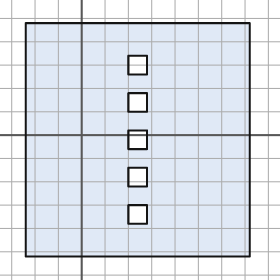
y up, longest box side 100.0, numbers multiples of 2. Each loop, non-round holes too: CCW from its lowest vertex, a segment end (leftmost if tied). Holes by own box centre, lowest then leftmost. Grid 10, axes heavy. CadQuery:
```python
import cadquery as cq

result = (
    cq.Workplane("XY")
    .moveTo(-24.0, -52.0)
    .lineTo(72.0, -52.0)
    .lineTo(72.0, 48.0)
    .lineTo(-24.0, 48.0)
    .close()
    .moveTo(20.0, -38.0)
    .lineTo(28.0, -38.0)
    .lineTo(28.0, -30.0)
    .lineTo(20.0, -30.0)
    .close()
    .moveTo(20.0, -22.0)
    .lineTo(28.0, -22.0)
    .lineTo(28.0, -14.0)
    .lineTo(20.0, -14.0)
    .close()
    .moveTo(20.0, -6.0)
    .lineTo(28.0, -6.0)
    .lineTo(28.0, 2.0)
    .lineTo(20.0, 2.0)
    .close()
    .moveTo(20.0, 10.0)
    .lineTo(28.0, 10.0)
    .lineTo(28.0, 18.0)
    .lineTo(20.0, 18.0)
    .close()
    .moveTo(20.0, 26.0)
    .lineTo(28.0, 26.0)
    .lineTo(28.0, 34.0)
    .lineTo(20.0, 34.0)
    .close()
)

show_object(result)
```